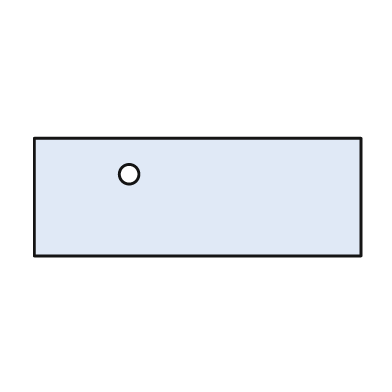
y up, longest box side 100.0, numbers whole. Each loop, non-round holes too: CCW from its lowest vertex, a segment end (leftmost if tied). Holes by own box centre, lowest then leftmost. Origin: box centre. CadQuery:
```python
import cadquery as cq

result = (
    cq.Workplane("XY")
    .moveTo(-50.0, -18.0)
    .lineTo(50.0, -18.0)
    .lineTo(50.0, 18.0)
    .lineTo(-50.0, 18.0)
    .close()
    .moveTo(-21.0, 7.0)
    .circle(3.0)
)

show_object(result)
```